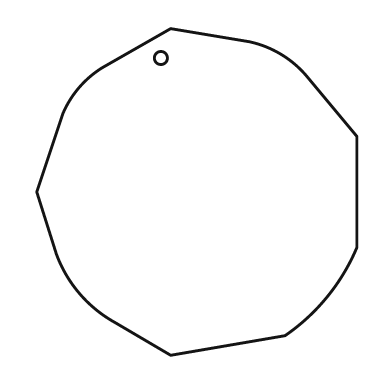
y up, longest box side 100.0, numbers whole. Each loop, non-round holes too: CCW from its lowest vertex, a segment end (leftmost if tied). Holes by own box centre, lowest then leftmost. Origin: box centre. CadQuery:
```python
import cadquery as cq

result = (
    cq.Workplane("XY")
    .moveTo(-8.0, -50.0)
    .lineTo(27.0, -44.0)
    .threePointArc((40.0, -32.0), (49.0, -17.0))
    .lineTo(49.0, 17.0)
    .lineTo(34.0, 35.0)
    .threePointArc((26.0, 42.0), (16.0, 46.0))
    .lineTo(-8.0, 50.0)
    .lineTo(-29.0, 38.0)
    .threePointArc((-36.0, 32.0), (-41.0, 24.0))
    .lineTo(-49.0, 0.0)
    .lineTo(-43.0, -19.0)
    .threePointArc((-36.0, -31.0), (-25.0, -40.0))
    .close()
    .moveTo(-11.0, 41.0)
    .circle(2.0)
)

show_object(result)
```